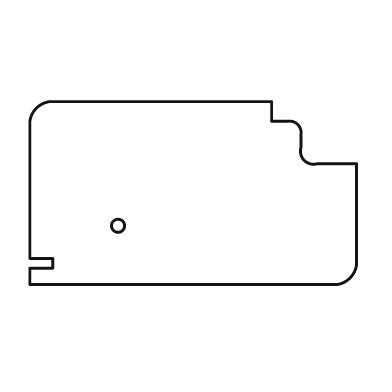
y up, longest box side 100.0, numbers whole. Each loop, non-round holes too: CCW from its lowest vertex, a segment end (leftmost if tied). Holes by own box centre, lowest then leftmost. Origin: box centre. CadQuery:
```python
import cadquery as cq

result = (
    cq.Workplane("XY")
    .moveTo(-50.0, -28.0)
    .lineTo(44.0, -28.0)
    .threePointArc((48.0, -26.0), (50.0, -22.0))
    .lineTo(50.0, 9.0)
    .lineTo(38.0, 9.0)
    .threePointArc((34.0, 10.0), (33.0, 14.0))
    .lineTo(33.0, 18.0)
    .threePointArc((32.0, 21.0), (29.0, 22.0))
    .lineTo(24.0, 22.0)
    .lineTo(24.0, 28.0)
    .lineTo(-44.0, 28.0)
    .threePointArc((-48.0, 26.0), (-50.0, 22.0))
    .lineTo(-50.0, -20.0)
    .lineTo(-43.0, -20.0)
    .lineTo(-43.0, -23.0)
    .lineTo(-50.0, -23.0)
    .close()
    .moveTo(-23.0, -10.0)
    .circle(2.0)
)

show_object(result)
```